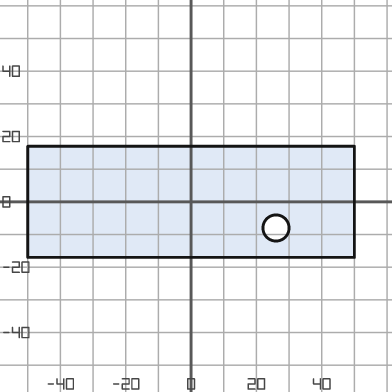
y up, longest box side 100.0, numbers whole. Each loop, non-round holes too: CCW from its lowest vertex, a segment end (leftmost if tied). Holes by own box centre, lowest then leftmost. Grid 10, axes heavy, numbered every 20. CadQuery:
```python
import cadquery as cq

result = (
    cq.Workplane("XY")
    .moveTo(-50.0, -17.0)
    .lineTo(50.0, -17.0)
    .lineTo(50.0, 17.0)
    .lineTo(-50.0, 17.0)
    .close()
    .moveTo(26.0, -8.0)
    .circle(4.0)
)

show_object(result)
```